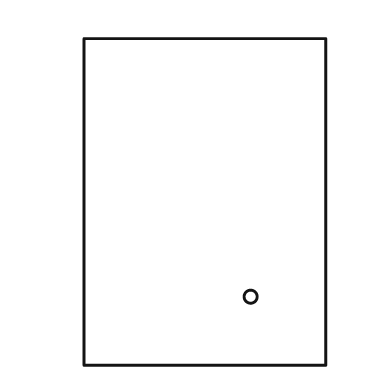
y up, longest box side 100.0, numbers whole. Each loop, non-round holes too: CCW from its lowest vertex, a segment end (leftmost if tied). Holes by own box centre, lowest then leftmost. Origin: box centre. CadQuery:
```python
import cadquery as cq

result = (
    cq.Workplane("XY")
    .moveTo(-37.0, -50.0)
    .lineTo(37.0, -50.0)
    .lineTo(37.0, 50.0)
    .lineTo(-37.0, 50.0)
    .close()
    .moveTo(14.0, -29.0)
    .circle(2.0)
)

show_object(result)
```